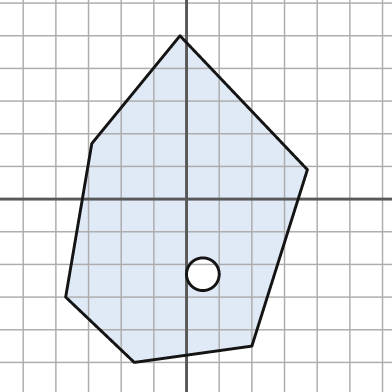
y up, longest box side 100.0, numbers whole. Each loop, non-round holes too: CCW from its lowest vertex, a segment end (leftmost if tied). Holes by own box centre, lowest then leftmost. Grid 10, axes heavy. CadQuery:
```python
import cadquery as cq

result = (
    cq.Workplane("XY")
    .moveTo(-16.0, -50.0)
    .lineTo(20.0, -45.0)
    .lineTo(37.0, 9.0)
    .lineTo(-2.0, 50.0)
    .lineTo(-29.0, 17.0)
    .lineTo(-37.0, -30.0)
    .close()
    .moveTo(5.0, -23.0)
    .circle(5.0)
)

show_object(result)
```